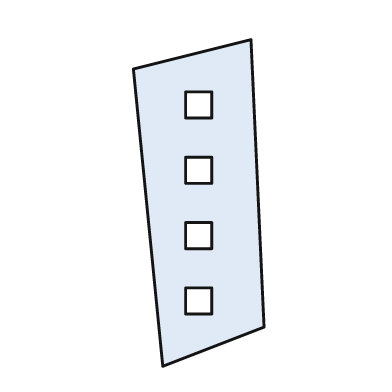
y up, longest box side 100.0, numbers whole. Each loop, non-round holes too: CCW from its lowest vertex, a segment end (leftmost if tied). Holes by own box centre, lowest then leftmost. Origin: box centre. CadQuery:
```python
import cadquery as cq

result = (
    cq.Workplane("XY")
    .moveTo(-11.0, -50.0)
    .lineTo(20.0, -38.0)
    .lineTo(16.0, 50.0)
    .lineTo(-20.0, 41.0)
    .close()
    .moveTo(-4.0, -34.0)
    .lineTo(4.0, -34.0)
    .lineTo(4.0, -26.0)
    .lineTo(-4.0, -26.0)
    .close()
    .moveTo(-4.0, -14.0)
    .lineTo(4.0, -14.0)
    .lineTo(4.0, -6.0)
    .lineTo(-4.0, -6.0)
    .close()
    .moveTo(-4.0, 6.0)
    .lineTo(4.0, 6.0)
    .lineTo(4.0, 14.0)
    .lineTo(-4.0, 14.0)
    .close()
    .moveTo(-4.0, 26.0)
    .lineTo(4.0, 26.0)
    .lineTo(4.0, 34.0)
    .lineTo(-4.0, 34.0)
    .close()
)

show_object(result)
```